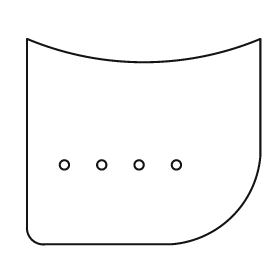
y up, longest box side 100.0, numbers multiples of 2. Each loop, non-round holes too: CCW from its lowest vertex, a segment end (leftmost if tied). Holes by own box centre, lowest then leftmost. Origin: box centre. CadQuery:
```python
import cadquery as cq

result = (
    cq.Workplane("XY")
    .moveTo(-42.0, -44.0)
    .lineTo(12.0, -44.0)
    .threePointArc((38.0, -32.0), (50.0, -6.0))
    .lineTo(50.0, 44.0)
    .threePointArc((0.0, 34.0), (-50.0, 44.0))
    .lineTo(-50.0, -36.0)
    .threePointArc((-48.0, -42.0), (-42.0, -44.0))
    .close()
    .moveTo(-34.0, -10.0)
    .circle(2.0)
    .moveTo(-18.0, -10.0)
    .circle(2.0)
    .moveTo(-2.0, -10.0)
    .circle(2.0)
    .moveTo(14.0, -10.0)
    .circle(2.0)
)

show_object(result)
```